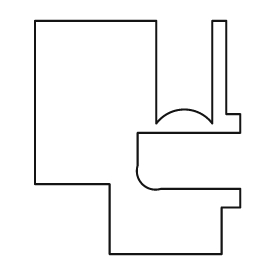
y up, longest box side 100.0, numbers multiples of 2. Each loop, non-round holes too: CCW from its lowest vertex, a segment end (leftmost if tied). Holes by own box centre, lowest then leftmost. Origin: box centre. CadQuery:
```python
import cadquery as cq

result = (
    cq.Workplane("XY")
    .moveTo(-12.0, -50.0)
    .lineTo(36.0, -50.0)
    .lineTo(36.0, -30.0)
    .lineTo(44.0, -30.0)
    .lineTo(44.0, -22.0)
    .lineTo(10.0, -22.0)
    .threePointArc((2.0, -20.0), (0.0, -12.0))
    .lineTo(0.0, 2.0)
    .lineTo(44.0, 2.0)
    .lineTo(44.0, 10.0)
    .lineTo(38.0, 10.0)
    .lineTo(38.0, 50.0)
    .lineTo(32.0, 50.0)
    .lineTo(32.0, 6.0)
    .threePointArc((20.0, 12.0), (8.0, 6.0))
    .lineTo(8.0, 50.0)
    .lineTo(-44.0, 50.0)
    .lineTo(-44.0, -20.0)
    .lineTo(-12.0, -20.0)
    .close()
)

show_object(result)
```